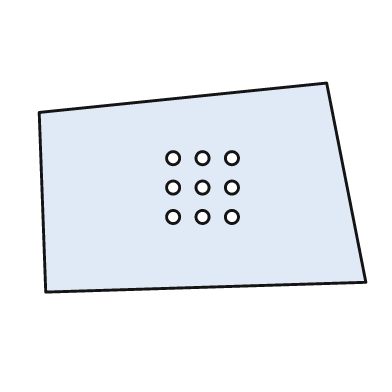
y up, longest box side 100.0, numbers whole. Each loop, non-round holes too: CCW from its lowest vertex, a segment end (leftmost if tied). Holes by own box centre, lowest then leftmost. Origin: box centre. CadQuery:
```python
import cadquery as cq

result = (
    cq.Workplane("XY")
    .moveTo(-48.0, -32.0)
    .lineTo(50.0, -29.0)
    .lineTo(38.0, 32.0)
    .lineTo(-50.0, 23.0)
    .close()
    .moveTo(-9.0, -9.0)
    .circle(2.0)
    .moveTo(0.0, -9.0)
    .circle(2.0)
    .moveTo(9.0, -9.0)
    .circle(2.0)
    .moveTo(-9.0, 0.0)
    .circle(2.0)
    .moveTo(0.0, 0.0)
    .circle(2.0)
    .moveTo(9.0, 0.0)
    .circle(2.0)
    .moveTo(-9.0, 9.0)
    .circle(2.0)
    .moveTo(0.0, 9.0)
    .circle(2.0)
    .moveTo(9.0, 9.0)
    .circle(2.0)
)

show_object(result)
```